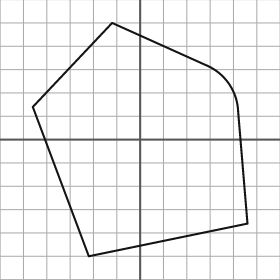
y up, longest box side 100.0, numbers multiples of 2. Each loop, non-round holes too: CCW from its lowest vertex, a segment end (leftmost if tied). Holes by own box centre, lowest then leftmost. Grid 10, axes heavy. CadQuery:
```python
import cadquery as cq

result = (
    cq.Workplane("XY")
    .moveTo(-22.0, -50.0)
    .lineTo(46.0, -36.0)
    .lineTo(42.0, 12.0)
    .threePointArc((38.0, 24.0), (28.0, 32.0))
    .lineTo(-12.0, 50.0)
    .lineTo(-46.0, 14.0)
    .close()
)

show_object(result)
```